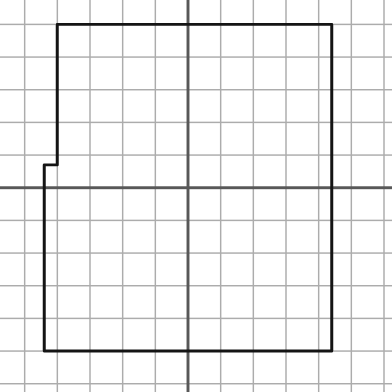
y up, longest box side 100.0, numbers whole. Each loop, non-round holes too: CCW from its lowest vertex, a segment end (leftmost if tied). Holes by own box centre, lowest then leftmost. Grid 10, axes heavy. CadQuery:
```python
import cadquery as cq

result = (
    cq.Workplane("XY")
    .moveTo(-44.0, -50.0)
    .lineTo(44.0, -50.0)
    .lineTo(44.0, 50.0)
    .lineTo(-40.0, 50.0)
    .lineTo(-40.0, 7.0)
    .lineTo(-44.0, 7.0)
    .close()
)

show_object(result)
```